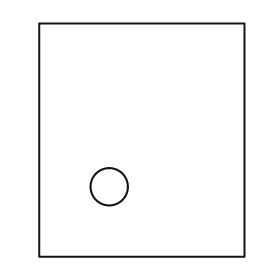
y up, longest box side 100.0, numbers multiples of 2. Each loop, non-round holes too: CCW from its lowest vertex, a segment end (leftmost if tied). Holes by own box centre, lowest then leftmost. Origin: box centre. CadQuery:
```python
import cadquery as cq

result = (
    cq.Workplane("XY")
    .moveTo(-44.0, -50.0)
    .lineTo(44.0, -50.0)
    .lineTo(44.0, 50.0)
    .lineTo(-44.0, 50.0)
    .close()
    .moveTo(-14.0, -20.0)
    .circle(8.0)
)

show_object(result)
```